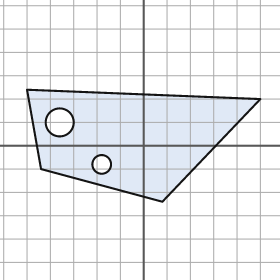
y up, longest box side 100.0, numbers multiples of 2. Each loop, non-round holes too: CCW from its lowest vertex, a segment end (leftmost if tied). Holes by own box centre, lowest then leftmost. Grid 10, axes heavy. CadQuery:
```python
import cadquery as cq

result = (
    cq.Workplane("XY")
    .moveTo(8.0, -24.0)
    .lineTo(50.0, 20.0)
    .lineTo(-50.0, 24.0)
    .lineTo(-44.0, -10.0)
    .close()
    .moveTo(-18.0, -8.0)
    .circle(4.0)
    .moveTo(-36.0, 10.0)
    .circle(6.0)
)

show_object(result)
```